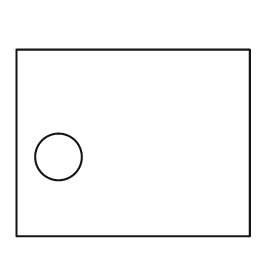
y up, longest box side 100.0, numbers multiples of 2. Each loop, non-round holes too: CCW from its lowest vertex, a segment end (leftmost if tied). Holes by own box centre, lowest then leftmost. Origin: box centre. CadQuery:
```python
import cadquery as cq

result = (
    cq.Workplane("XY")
    .moveTo(-50.0, -40.0)
    .lineTo(50.0, -40.0)
    .lineTo(50.0, 40.0)
    .lineTo(-50.0, 40.0)
    .close()
    .moveTo(-32.0, -6.0)
    .circle(10.0)
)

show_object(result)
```